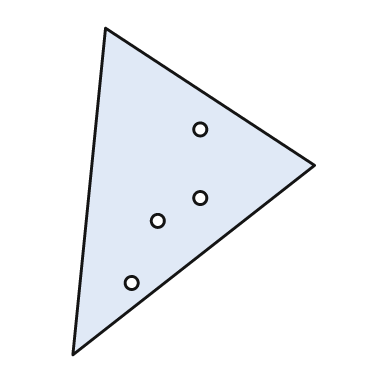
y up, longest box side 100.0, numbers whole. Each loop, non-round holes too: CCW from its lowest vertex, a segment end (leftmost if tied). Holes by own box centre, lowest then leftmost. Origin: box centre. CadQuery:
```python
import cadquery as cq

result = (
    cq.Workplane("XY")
    .moveTo(-37.0, -50.0)
    .lineTo(37.0, 8.0)
    .lineTo(-27.0, 50.0)
    .close()
    .moveTo(-19.0, -28.0)
    .circle(2.0)
    .moveTo(-11.0, -9.0)
    .circle(2.0)
    .moveTo(2.0, -2.0)
    .circle(2.0)
    .moveTo(2.0, 19.0)
    .circle(2.0)
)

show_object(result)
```